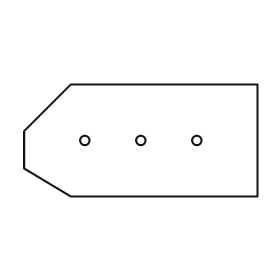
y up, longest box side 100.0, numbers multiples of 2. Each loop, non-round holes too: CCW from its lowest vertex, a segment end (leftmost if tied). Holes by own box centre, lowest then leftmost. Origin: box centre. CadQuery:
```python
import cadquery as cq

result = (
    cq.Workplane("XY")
    .moveTo(-30.0, -24.0)
    .lineTo(50.0, -24.0)
    .lineTo(50.0, 24.0)
    .lineTo(-30.0, 24.0)
    .lineTo(-50.0, 4.0)
    .lineTo(-50.0, -12.0)
    .close()
    .moveTo(-24.0, 0.0)
    .circle(2.0)
    .moveTo(0.0, 0.0)
    .circle(2.0)
    .moveTo(24.0, 0.0)
    .circle(2.0)
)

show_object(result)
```